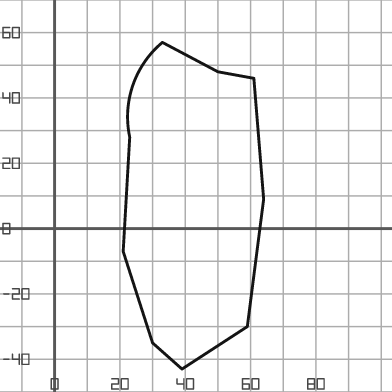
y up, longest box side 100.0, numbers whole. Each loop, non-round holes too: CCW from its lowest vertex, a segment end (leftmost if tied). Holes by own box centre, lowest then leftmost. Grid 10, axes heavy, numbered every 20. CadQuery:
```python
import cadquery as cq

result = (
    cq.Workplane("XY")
    .moveTo(39.0, -43.0)
    .lineTo(59.0, -30.0)
    .lineTo(64.0, 9.0)
    .lineTo(61.0, 46.0)
    .lineTo(50.0, 48.0)
    .lineTo(33.0, 57.0)
    .threePointArc((24.0, 44.0), (23.0, 28.0))
    .lineTo(21.0, -7.0)
    .lineTo(30.0, -35.0)
    .close()
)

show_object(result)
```